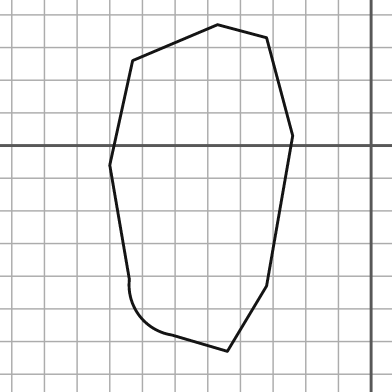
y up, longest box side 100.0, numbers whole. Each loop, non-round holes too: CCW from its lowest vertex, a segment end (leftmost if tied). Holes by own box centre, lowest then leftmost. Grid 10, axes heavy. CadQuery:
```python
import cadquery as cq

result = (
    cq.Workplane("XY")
    .moveTo(-44.0, -63.0)
    .lineTo(-32.0, -43.0)
    .lineTo(-24.0, 3.0)
    .lineTo(-32.0, 33.0)
    .lineTo(-47.0, 37.0)
    .lineTo(-73.0, 26.0)
    .lineTo(-80.0, -6.0)
    .lineTo(-74.0, -41.0)
    .threePointArc((-71.0, -52.0), (-61.0, -58.0))
    .close()
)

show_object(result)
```